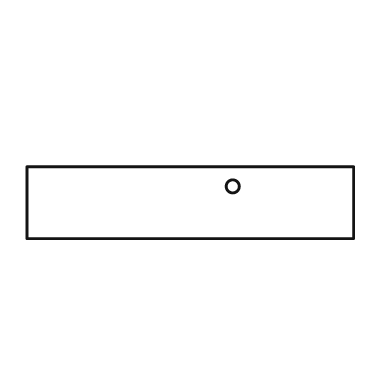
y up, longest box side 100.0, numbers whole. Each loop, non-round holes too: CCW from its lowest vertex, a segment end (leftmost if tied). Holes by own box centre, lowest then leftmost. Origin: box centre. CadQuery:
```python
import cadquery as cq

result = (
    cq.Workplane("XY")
    .moveTo(-50.0, -11.0)
    .lineTo(50.0, -11.0)
    .lineTo(50.0, 11.0)
    .lineTo(-50.0, 11.0)
    .close()
    .moveTo(13.0, 5.0)
    .circle(2.0)
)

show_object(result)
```